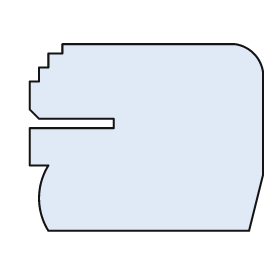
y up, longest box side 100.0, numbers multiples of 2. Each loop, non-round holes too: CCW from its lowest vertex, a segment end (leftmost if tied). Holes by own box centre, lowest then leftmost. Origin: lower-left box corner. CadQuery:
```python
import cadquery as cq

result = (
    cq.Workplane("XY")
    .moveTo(8.0, 0.0)
    .lineTo(94.0, 0.0)
    .lineTo(100.0, 24.0)
    .lineTo(100.0, 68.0)
    .threePointArc((96.0, 76.0), (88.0, 80.0))
    .lineTo(14.0, 80.0)
    .lineTo(14.0, 76.0)
    .lineTo(8.0, 76.0)
    .lineTo(8.0, 70.0)
    .lineTo(4.0, 70.0)
    .lineTo(4.0, 64.0)
    .lineTo(0.0, 64.0)
    .lineTo(0.0, 52.0)
    .lineTo(4.0, 48.0)
    .lineTo(36.0, 48.0)
    .lineTo(36.0, 44.0)
    .lineTo(0.0, 44.0)
    .lineTo(0.0, 28.0)
    .lineTo(8.0, 28.0)
    .threePointArc((4.0, 14.0), (8.0, 0.0))
    .close()
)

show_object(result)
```